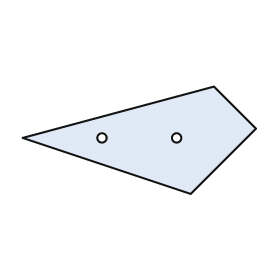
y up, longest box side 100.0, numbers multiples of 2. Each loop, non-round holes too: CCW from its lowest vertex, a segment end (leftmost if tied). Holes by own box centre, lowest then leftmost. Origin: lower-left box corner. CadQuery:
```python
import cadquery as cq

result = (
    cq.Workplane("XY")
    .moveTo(72.0, 0.0)
    .lineTo(100.0, 28.0)
    .lineTo(82.0, 46.0)
    .lineTo(0.0, 24.0)
    .close()
    .moveTo(34.0, 24.0)
    .circle(2.0)
    .moveTo(66.0, 24.0)
    .circle(2.0)
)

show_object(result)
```